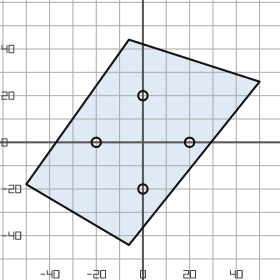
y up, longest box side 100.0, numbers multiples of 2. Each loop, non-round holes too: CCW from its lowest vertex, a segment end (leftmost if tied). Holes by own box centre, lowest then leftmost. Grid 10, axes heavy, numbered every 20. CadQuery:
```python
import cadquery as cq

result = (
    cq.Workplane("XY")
    .moveTo(-6.0, -44.0)
    .lineTo(50.0, 26.0)
    .lineTo(-6.0, 44.0)
    .lineTo(-50.0, -18.0)
    .close()
    .moveTo(0.0, -20.0)
    .circle(2.0)
    .moveTo(-20.0, 0.0)
    .circle(2.0)
    .moveTo(20.0, 0.0)
    .circle(2.0)
    .moveTo(0.0, 20.0)
    .circle(2.0)
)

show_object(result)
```